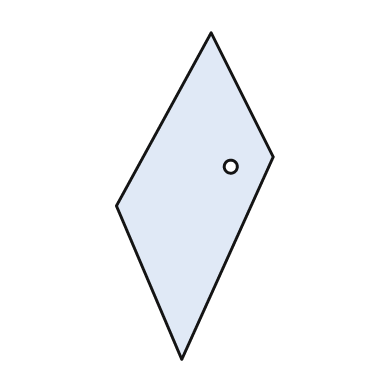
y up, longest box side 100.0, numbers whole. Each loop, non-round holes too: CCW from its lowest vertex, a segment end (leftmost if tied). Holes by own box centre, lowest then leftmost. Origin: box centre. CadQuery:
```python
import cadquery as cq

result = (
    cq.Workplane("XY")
    .moveTo(-4.0, -50.0)
    .lineTo(24.0, 12.0)
    .lineTo(5.0, 50.0)
    .lineTo(-24.0, -3.0)
    .close()
    .moveTo(11.0, 9.0)
    .circle(2.0)
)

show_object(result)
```